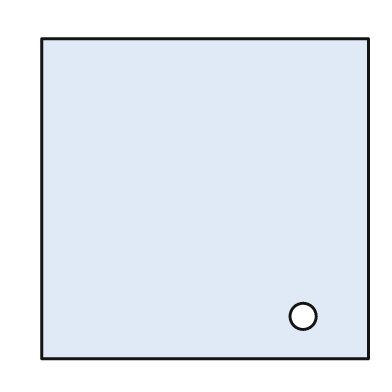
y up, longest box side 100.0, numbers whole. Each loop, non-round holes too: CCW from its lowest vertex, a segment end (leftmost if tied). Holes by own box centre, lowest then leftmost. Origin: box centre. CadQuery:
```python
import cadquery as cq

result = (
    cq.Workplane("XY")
    .moveTo(-50.0, -49.0)
    .lineTo(50.0, -49.0)
    .lineTo(50.0, 49.0)
    .lineTo(-50.0, 49.0)
    .close()
    .moveTo(30.0, -36.0)
    .circle(4.0)
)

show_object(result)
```